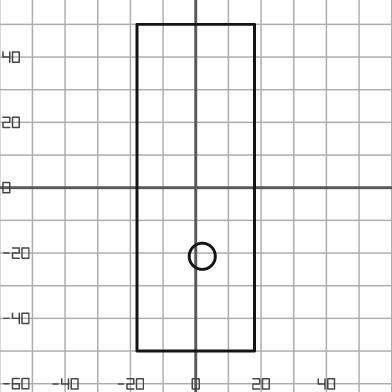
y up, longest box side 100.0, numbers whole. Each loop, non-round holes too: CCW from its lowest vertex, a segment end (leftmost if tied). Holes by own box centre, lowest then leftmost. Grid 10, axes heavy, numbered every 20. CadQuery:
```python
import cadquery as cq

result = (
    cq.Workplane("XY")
    .moveTo(-18.0, -50.0)
    .lineTo(18.0, -50.0)
    .lineTo(18.0, 50.0)
    .lineTo(-18.0, 50.0)
    .close()
    .moveTo(2.0, -21.0)
    .circle(4.0)
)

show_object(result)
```